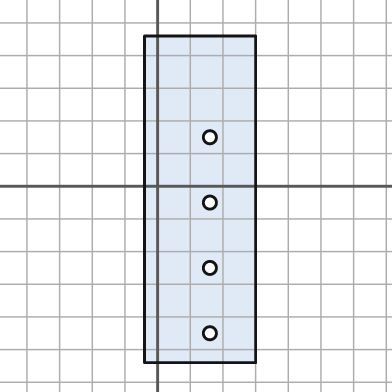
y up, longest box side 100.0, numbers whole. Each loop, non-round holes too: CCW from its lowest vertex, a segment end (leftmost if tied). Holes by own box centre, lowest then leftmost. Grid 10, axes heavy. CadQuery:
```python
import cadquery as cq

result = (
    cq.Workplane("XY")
    .moveTo(-4.0, -54.0)
    .lineTo(30.0, -54.0)
    .lineTo(30.0, 46.0)
    .lineTo(-4.0, 46.0)
    .close()
    .moveTo(16.0, -45.0)
    .circle(2.0)
    .moveTo(16.0, -25.0)
    .circle(2.0)
    .moveTo(16.0, -5.0)
    .circle(2.0)
    .moveTo(16.0, 15.0)
    .circle(2.0)
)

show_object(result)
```